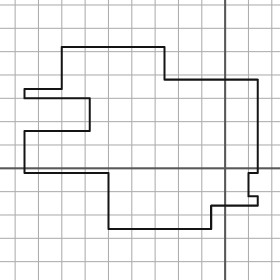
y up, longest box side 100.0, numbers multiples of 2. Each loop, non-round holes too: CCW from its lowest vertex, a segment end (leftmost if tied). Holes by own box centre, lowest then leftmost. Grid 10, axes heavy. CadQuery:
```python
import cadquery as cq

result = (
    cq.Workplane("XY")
    .moveTo(-50.0, -26.0)
    .lineTo(-6.0, -26.0)
    .lineTo(-6.0, -16.0)
    .lineTo(14.0, -16.0)
    .lineTo(14.0, -12.0)
    .lineTo(10.0, -12.0)
    .lineTo(10.0, -2.0)
    .lineTo(14.0, -2.0)
    .lineTo(14.0, 38.0)
    .lineTo(-26.0, 38.0)
    .lineTo(-26.0, 52.0)
    .lineTo(-70.0, 52.0)
    .lineTo(-70.0, 34.0)
    .lineTo(-86.0, 34.0)
    .lineTo(-86.0, 30.0)
    .lineTo(-58.0, 30.0)
    .lineTo(-58.0, 16.0)
    .lineTo(-86.0, 16.0)
    .lineTo(-86.0, -2.0)
    .lineTo(-50.0, -2.0)
    .close()
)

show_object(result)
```